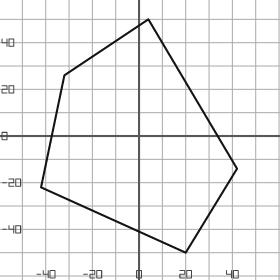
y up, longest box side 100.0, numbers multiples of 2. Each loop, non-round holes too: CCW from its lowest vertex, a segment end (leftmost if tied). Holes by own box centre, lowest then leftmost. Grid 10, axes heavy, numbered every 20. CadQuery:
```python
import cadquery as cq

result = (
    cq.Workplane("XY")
    .moveTo(20.0, -50.0)
    .lineTo(42.0, -14.0)
    .lineTo(4.0, 50.0)
    .lineTo(-32.0, 26.0)
    .lineTo(-42.0, -22.0)
    .close()
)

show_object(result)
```